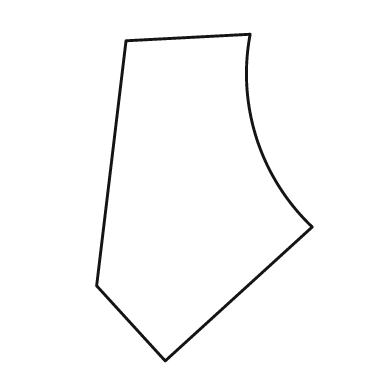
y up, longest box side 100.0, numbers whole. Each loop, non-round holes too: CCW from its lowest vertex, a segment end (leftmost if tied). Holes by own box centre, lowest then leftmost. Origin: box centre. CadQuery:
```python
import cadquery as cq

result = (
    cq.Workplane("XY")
    .moveTo(-12.0, -50.0)
    .lineTo(33.0, -9.0)
    .threePointArc((16.0, 18.0), (14.0, 50.0))
    .lineTo(-24.0, 48.0)
    .lineTo(-33.0, -27.0)
    .close()
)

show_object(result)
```